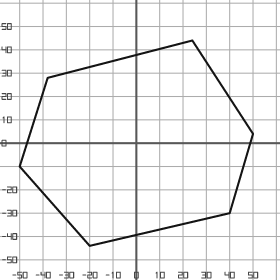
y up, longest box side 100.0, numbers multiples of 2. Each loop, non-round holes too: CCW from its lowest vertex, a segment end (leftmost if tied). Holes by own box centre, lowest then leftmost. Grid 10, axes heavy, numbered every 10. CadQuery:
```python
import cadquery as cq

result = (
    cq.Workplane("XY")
    .moveTo(-20.0, -44.0)
    .lineTo(40.0, -30.0)
    .lineTo(50.0, 4.0)
    .lineTo(24.0, 44.0)
    .lineTo(-38.0, 28.0)
    .lineTo(-50.0, -10.0)
    .close()
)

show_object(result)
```